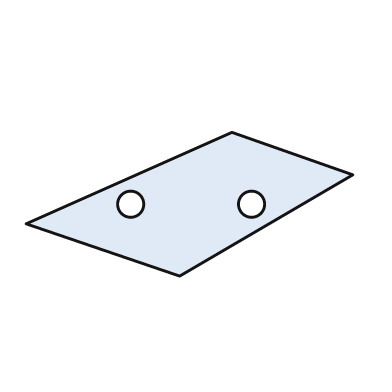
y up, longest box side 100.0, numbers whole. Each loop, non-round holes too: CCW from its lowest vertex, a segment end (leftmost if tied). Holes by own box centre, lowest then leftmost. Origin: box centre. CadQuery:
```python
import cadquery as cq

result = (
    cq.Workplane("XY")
    .moveTo(-3.0, -22.0)
    .lineTo(50.0, 9.0)
    .lineTo(13.0, 22.0)
    .lineTo(-50.0, -6.0)
    .close()
    .moveTo(-18.0, 0.0)
    .circle(4.0)
    .moveTo(19.0, 0.0)
    .circle(4.0)
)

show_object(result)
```